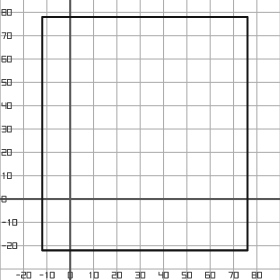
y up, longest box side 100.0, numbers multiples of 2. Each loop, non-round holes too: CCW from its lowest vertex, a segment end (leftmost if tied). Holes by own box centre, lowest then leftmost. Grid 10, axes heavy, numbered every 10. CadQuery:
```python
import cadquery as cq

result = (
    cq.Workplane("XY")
    .moveTo(-12.0, -22.0)
    .lineTo(76.0, -22.0)
    .lineTo(76.0, 78.0)
    .lineTo(-12.0, 78.0)
    .close()
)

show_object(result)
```